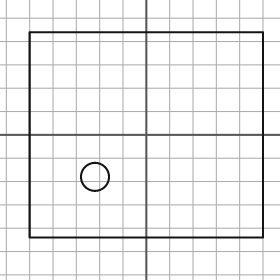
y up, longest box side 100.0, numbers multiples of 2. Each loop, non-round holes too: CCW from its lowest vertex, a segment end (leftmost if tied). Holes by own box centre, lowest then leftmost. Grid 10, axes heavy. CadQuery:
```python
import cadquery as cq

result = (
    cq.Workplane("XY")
    .moveTo(-50.0, -44.0)
    .lineTo(50.0, -44.0)
    .lineTo(50.0, 44.0)
    .lineTo(-50.0, 44.0)
    .close()
    .moveTo(-22.0, -18.0)
    .circle(6.0)
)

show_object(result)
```